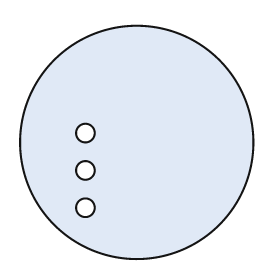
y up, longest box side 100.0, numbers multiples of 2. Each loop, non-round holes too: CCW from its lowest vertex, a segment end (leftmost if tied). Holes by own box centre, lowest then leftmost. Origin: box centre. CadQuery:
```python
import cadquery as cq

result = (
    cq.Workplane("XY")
    .moveTo(0.0, 0.0)
    .circle(50.0)
    .moveTo(-22.0, -28.0)
    .circle(4.0)
    .moveTo(-22.0, -12.0)
    .circle(4.0)
    .moveTo(-22.0, 4.0)
    .circle(4.0)
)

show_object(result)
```